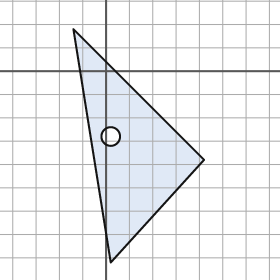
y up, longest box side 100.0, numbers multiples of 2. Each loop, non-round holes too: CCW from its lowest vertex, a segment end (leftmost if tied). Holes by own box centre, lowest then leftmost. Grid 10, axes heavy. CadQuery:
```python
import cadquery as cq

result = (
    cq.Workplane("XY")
    .moveTo(2.0, -82.0)
    .lineTo(42.0, -38.0)
    .lineTo(-14.0, 18.0)
    .close()
    .moveTo(2.0, -28.0)
    .circle(4.0)
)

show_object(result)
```